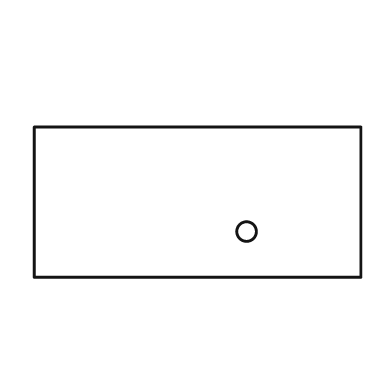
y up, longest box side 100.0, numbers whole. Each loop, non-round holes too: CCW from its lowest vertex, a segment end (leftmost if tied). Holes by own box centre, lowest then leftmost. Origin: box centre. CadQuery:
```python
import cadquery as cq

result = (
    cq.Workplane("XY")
    .moveTo(-50.0, -23.0)
    .lineTo(50.0, -23.0)
    .lineTo(50.0, 23.0)
    .lineTo(-50.0, 23.0)
    .close()
    .moveTo(15.0, -9.0)
    .circle(3.0)
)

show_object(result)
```